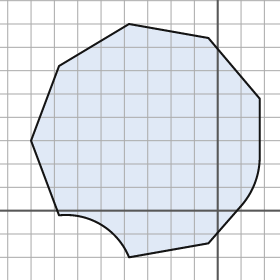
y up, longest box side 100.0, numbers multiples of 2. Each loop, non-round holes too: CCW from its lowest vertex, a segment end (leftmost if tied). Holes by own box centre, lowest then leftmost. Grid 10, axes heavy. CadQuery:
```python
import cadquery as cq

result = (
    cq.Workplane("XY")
    .moveTo(-38.0, -20.0)
    .lineTo(-4.0, -14.0)
    .lineTo(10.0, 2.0)
    .threePointArc((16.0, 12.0), (18.0, 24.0))
    .lineTo(18.0, 48.0)
    .lineTo(-4.0, 74.0)
    .lineTo(-38.0, 80.0)
    .lineTo(-68.0, 62.0)
    .lineTo(-80.0, 30.0)
    .lineTo(-68.0, -2.0)
    .threePointArc((-50.0, -6.0), (-38.0, -20.0))
    .close()
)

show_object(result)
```